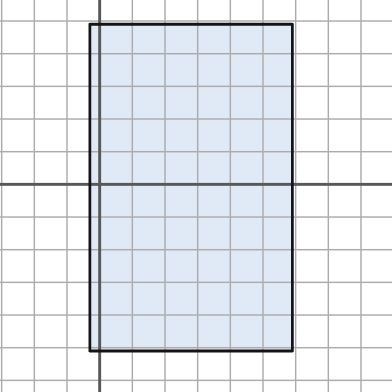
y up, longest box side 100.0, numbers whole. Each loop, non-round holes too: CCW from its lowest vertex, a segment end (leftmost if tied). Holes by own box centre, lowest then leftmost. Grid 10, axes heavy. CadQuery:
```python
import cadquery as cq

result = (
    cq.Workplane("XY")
    .moveTo(-3.0, -51.0)
    .lineTo(59.0, -51.0)
    .lineTo(59.0, 49.0)
    .lineTo(-3.0, 49.0)
    .close()
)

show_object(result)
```